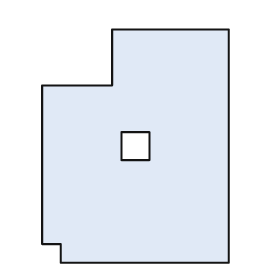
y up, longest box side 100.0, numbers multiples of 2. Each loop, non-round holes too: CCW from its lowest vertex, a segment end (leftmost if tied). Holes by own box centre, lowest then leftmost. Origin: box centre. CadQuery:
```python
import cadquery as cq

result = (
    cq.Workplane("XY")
    .moveTo(-32.0, -50.0)
    .lineTo(40.0, -50.0)
    .lineTo(40.0, 50.0)
    .lineTo(-10.0, 50.0)
    .lineTo(-10.0, 26.0)
    .lineTo(-40.0, 26.0)
    .lineTo(-40.0, -42.0)
    .lineTo(-32.0, -42.0)
    .close()
    .moveTo(-6.0, -6.0)
    .lineTo(6.0, -6.0)
    .lineTo(6.0, 6.0)
    .lineTo(-6.0, 6.0)
    .close()
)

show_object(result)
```